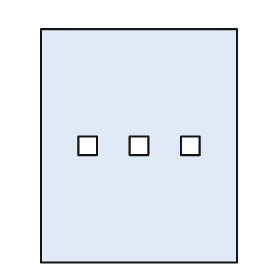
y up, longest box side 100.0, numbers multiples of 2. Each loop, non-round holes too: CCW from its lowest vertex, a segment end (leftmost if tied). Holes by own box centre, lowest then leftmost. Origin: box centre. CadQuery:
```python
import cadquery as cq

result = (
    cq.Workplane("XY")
    .moveTo(-42.0, -50.0)
    .lineTo(42.0, -50.0)
    .lineTo(42.0, 50.0)
    .lineTo(-42.0, 50.0)
    .close()
    .moveTo(-26.0, -4.0)
    .lineTo(-18.0, -4.0)
    .lineTo(-18.0, 4.0)
    .lineTo(-26.0, 4.0)
    .close()
    .moveTo(-4.0, -4.0)
    .lineTo(4.0, -4.0)
    .lineTo(4.0, 4.0)
    .lineTo(-4.0, 4.0)
    .close()
    .moveTo(18.0, -4.0)
    .lineTo(26.0, -4.0)
    .lineTo(26.0, 4.0)
    .lineTo(18.0, 4.0)
    .close()
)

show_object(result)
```